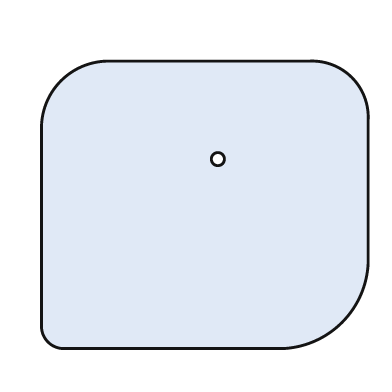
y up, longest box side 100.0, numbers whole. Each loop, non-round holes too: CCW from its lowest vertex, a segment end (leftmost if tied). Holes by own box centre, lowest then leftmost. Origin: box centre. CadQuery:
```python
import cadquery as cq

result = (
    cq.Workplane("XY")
    .moveTo(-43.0, -44.0)
    .lineTo(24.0, -44.0)
    .threePointArc((42.0, -36.0), (50.0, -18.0))
    .lineTo(50.0, 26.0)
    .threePointArc((45.0, 39.0), (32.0, 44.0))
    .lineTo(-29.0, 44.0)
    .threePointArc((-44.0, 38.0), (-50.0, 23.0))
    .lineTo(-50.0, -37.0)
    .threePointArc((-48.0, -42.0), (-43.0, -44.0))
    .close()
    .moveTo(4.0, 14.0)
    .circle(2.0)
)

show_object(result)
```